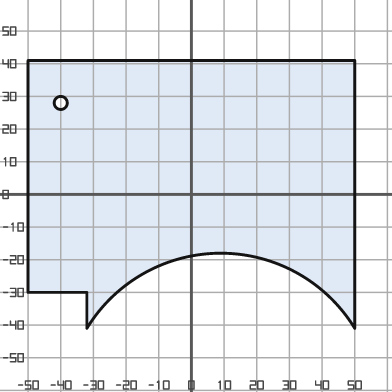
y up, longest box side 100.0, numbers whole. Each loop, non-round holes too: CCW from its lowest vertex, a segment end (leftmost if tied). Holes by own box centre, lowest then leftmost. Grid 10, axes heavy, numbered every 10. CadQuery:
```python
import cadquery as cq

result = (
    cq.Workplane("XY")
    .moveTo(-32.0, -41.0)
    .threePointArc((9.0, -18.0), (50.0, -41.0))
    .lineTo(50.0, 41.0)
    .lineTo(-50.0, 41.0)
    .lineTo(-50.0, -30.0)
    .lineTo(-32.0, -30.0)
    .close()
    .moveTo(-40.0, 28.0)
    .circle(2.0)
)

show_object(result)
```